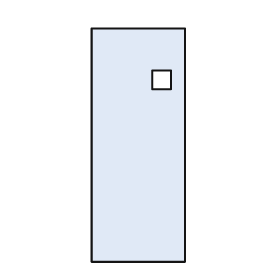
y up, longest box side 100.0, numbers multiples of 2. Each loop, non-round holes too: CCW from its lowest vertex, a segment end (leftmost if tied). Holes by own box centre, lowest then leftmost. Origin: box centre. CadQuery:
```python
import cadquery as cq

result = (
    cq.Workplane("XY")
    .moveTo(-20.0, -50.0)
    .lineTo(20.0, -50.0)
    .lineTo(20.0, 50.0)
    .lineTo(-20.0, 50.0)
    .close()
    .moveTo(6.0, 24.0)
    .lineTo(14.0, 24.0)
    .lineTo(14.0, 32.0)
    .lineTo(6.0, 32.0)
    .close()
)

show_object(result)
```